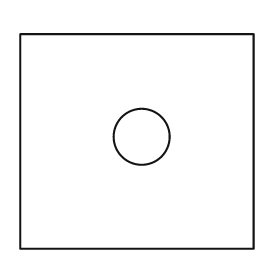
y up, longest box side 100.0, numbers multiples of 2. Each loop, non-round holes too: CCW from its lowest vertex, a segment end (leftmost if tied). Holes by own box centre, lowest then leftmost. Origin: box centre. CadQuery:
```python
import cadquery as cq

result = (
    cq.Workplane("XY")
    .moveTo(-50.0, -46.0)
    .lineTo(50.0, -46.0)
    .lineTo(50.0, 46.0)
    .lineTo(-50.0, 46.0)
    .close()
    .moveTo(2.0, 2.0)
    .circle(12.0)
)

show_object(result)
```